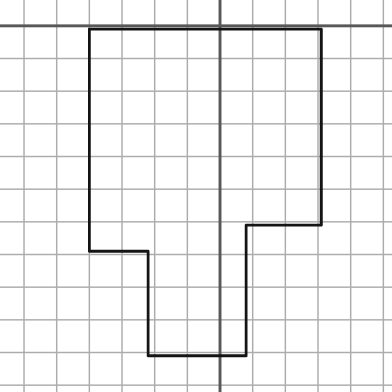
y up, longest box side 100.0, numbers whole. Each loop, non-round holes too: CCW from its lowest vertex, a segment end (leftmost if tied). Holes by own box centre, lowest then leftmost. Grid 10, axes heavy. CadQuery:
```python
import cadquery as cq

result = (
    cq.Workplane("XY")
    .moveTo(-22.0, -101.0)
    .lineTo(8.0, -101.0)
    .lineTo(8.0, -61.0)
    .lineTo(31.0, -61.0)
    .lineTo(31.0, -1.0)
    .lineTo(-40.0, -1.0)
    .lineTo(-40.0, -69.0)
    .lineTo(-22.0, -69.0)
    .close()
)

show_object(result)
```